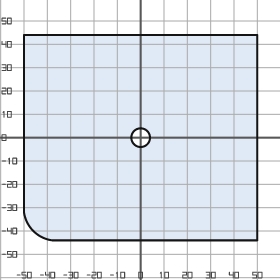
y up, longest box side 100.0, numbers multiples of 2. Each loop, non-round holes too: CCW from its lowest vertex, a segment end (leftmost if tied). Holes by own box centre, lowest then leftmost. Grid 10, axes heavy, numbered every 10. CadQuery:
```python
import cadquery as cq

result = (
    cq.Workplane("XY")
    .moveTo(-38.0, -44.0)
    .lineTo(50.0, -44.0)
    .lineTo(50.0, 44.0)
    .lineTo(-50.0, 44.0)
    .lineTo(-50.0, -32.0)
    .threePointArc((-46.0, -40.0), (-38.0, -44.0))
    .close()
    .moveTo(0.0, 0.0)
    .circle(4.0)
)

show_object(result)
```